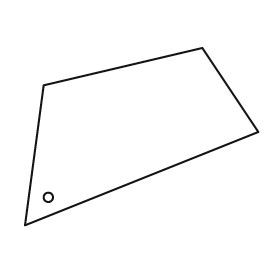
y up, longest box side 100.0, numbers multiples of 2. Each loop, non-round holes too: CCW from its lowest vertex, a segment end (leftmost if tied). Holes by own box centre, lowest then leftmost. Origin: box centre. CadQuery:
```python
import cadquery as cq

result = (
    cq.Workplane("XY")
    .moveTo(-50.0, -38.0)
    .lineTo(50.0, 2.0)
    .lineTo(26.0, 38.0)
    .lineTo(-42.0, 22.0)
    .close()
    .moveTo(-40.0, -26.0)
    .circle(2.0)
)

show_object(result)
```